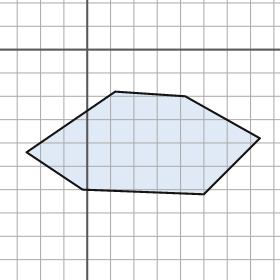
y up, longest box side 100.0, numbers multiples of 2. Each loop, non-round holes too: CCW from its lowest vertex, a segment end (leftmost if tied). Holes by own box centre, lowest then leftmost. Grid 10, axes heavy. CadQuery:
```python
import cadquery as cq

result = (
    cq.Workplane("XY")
    .moveTo(50.0, -62.0)
    .lineTo(74.0, -38.0)
    .lineTo(42.0, -20.0)
    .lineTo(12.0, -18.0)
    .lineTo(-26.0, -44.0)
    .lineTo(-2.0, -60.0)
    .close()
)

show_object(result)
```